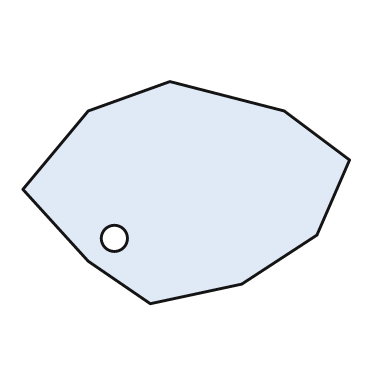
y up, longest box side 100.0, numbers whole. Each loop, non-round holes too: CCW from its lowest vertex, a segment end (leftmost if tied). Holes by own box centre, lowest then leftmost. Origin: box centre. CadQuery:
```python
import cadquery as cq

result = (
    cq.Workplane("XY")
    .moveTo(-11.0, -34.0)
    .lineTo(17.0, -28.0)
    .lineTo(40.0, -13.0)
    .lineTo(50.0, 10.0)
    .lineTo(30.0, 25.0)
    .lineTo(-5.0, 34.0)
    .lineTo(-30.0, 25.0)
    .lineTo(-50.0, 1.0)
    .lineTo(-30.0, -21.0)
    .close()
    .moveTo(-22.0, -14.0)
    .circle(4.0)
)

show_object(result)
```